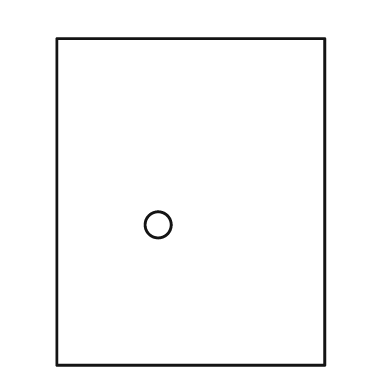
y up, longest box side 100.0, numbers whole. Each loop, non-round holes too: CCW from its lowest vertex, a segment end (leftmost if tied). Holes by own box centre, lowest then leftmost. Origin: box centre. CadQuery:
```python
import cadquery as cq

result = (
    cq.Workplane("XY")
    .moveTo(-41.0, -50.0)
    .lineTo(41.0, -50.0)
    .lineTo(41.0, 50.0)
    .lineTo(-41.0, 50.0)
    .close()
    .moveTo(-10.0, -7.0)
    .circle(4.0)
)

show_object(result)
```